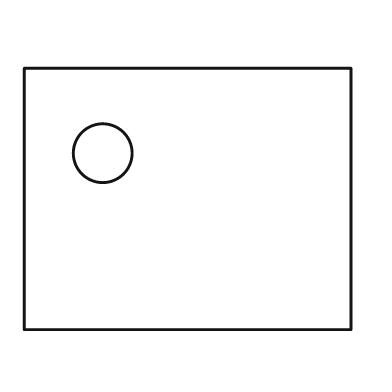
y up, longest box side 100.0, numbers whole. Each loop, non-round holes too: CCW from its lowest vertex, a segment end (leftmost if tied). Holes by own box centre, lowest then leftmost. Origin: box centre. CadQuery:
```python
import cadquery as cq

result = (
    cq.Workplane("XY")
    .moveTo(-50.0, -40.0)
    .lineTo(50.0, -40.0)
    .lineTo(50.0, 40.0)
    .lineTo(-50.0, 40.0)
    .close()
    .moveTo(-26.0, 14.0)
    .circle(9.0)
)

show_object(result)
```